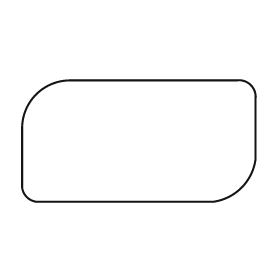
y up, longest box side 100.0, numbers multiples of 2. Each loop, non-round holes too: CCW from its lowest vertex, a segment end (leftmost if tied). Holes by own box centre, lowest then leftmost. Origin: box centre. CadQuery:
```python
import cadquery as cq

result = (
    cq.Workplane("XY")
    .moveTo(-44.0, -26.0)
    .lineTo(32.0, -26.0)
    .threePointArc((44.0, -20.0), (50.0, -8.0))
    .lineTo(50.0, 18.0)
    .threePointArc((48.0, 24.0), (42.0, 26.0))
    .lineTo(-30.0, 26.0)
    .threePointArc((-44.0, 20.0), (-50.0, 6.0))
    .lineTo(-50.0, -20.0)
    .threePointArc((-48.0, -24.0), (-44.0, -26.0))
    .close()
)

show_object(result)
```